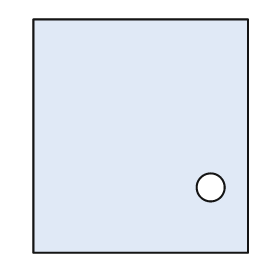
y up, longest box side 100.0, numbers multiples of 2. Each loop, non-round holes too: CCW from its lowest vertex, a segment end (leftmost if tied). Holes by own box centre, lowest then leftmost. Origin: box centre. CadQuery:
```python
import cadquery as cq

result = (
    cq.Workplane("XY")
    .moveTo(-46.0, -50.0)
    .lineTo(46.0, -50.0)
    .lineTo(46.0, 50.0)
    .lineTo(-46.0, 50.0)
    .close()
    .moveTo(30.0, -22.0)
    .circle(6.0)
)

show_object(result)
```